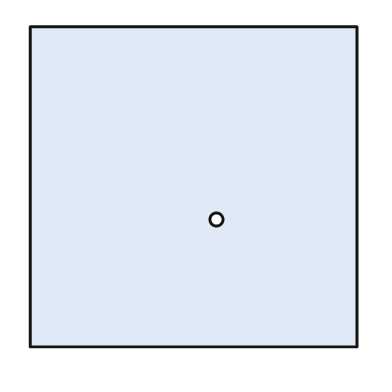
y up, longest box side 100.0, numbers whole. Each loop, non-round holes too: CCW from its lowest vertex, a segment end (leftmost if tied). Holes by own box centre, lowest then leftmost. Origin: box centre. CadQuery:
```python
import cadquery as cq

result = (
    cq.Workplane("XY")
    .moveTo(-50.0, -49.0)
    .lineTo(50.0, -49.0)
    .lineTo(50.0, 49.0)
    .lineTo(-50.0, 49.0)
    .close()
    .moveTo(7.0, -10.0)
    .circle(2.0)
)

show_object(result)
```